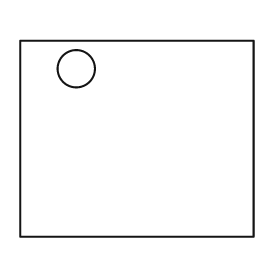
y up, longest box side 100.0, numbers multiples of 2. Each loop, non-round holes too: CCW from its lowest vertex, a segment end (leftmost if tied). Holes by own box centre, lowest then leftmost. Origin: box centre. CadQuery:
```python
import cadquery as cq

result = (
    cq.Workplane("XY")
    .moveTo(-50.0, -42.0)
    .lineTo(50.0, -42.0)
    .lineTo(50.0, 42.0)
    .lineTo(-50.0, 42.0)
    .close()
    .moveTo(-26.0, 30.0)
    .circle(8.0)
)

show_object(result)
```